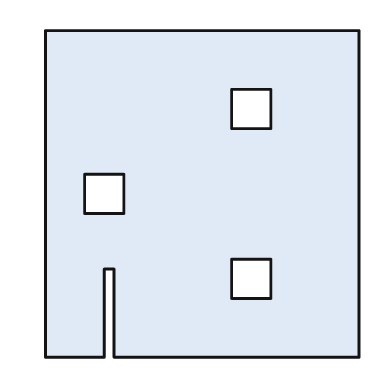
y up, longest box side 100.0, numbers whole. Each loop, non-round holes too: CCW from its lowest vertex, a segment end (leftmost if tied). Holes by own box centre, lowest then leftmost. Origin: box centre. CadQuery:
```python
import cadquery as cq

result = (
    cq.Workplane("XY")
    .moveTo(-48.0, -50.0)
    .lineTo(-30.0, -50.0)
    .lineTo(-30.0, -23.0)
    .lineTo(-27.0, -23.0)
    .lineTo(-27.0, -50.0)
    .lineTo(48.0, -50.0)
    .lineTo(48.0, 50.0)
    .lineTo(-48.0, 50.0)
    .close()
    .moveTo(9.0, -32.0)
    .lineTo(21.0, -32.0)
    .lineTo(21.0, -20.0)
    .lineTo(9.0, -20.0)
    .close()
    .moveTo(-36.0, -6.0)
    .lineTo(-24.0, -6.0)
    .lineTo(-24.0, 6.0)
    .lineTo(-36.0, 6.0)
    .close()
    .moveTo(9.0, 20.0)
    .lineTo(21.0, 20.0)
    .lineTo(21.0, 32.0)
    .lineTo(9.0, 32.0)
    .close()
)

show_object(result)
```